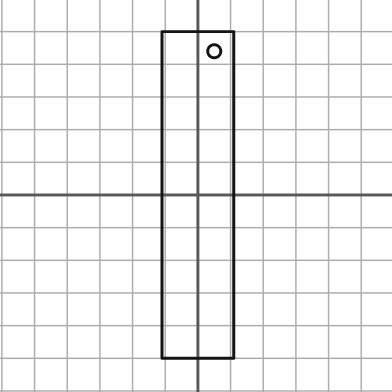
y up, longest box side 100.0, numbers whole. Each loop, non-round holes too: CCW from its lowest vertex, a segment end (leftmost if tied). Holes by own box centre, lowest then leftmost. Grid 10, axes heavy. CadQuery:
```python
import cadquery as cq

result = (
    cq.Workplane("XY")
    .moveTo(-11.0, -50.0)
    .lineTo(11.0, -50.0)
    .lineTo(11.0, 50.0)
    .lineTo(-11.0, 50.0)
    .close()
    .moveTo(5.0, 44.0)
    .circle(2.0)
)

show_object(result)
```